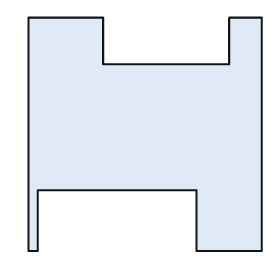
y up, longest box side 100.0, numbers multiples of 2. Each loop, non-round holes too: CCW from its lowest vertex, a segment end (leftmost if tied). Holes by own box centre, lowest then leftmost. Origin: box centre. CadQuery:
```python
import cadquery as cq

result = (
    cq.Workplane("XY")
    .moveTo(-50.0, -50.0)
    .lineTo(-46.0, -50.0)
    .lineTo(-46.0, -24.0)
    .lineTo(22.0, -24.0)
    .lineTo(22.0, -50.0)
    .lineTo(50.0, -50.0)
    .lineTo(50.0, 50.0)
    .lineTo(36.0, 50.0)
    .lineTo(36.0, 30.0)
    .lineTo(-18.0, 30.0)
    .lineTo(-18.0, 50.0)
    .lineTo(-50.0, 50.0)
    .close()
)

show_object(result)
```